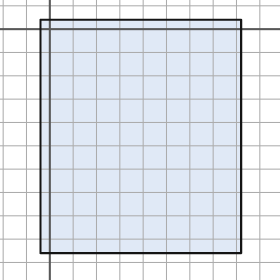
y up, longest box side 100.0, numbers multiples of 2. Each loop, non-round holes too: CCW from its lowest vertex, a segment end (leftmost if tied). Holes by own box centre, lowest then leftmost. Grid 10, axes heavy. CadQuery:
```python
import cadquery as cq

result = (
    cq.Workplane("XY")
    .moveTo(-4.0, -96.0)
    .lineTo(82.0, -96.0)
    .lineTo(82.0, 4.0)
    .lineTo(-4.0, 4.0)
    .close()
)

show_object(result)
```